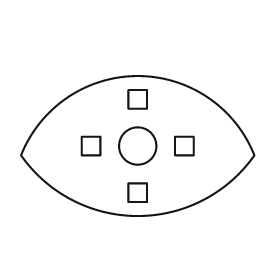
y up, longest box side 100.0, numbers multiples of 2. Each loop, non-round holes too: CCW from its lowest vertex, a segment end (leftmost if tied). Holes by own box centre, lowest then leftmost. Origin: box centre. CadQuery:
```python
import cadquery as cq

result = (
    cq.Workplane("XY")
    .moveTo(-50.0, -4.0)
    .threePointArc((0.0, -30.0), (50.0, -4.0))
    .threePointArc((0.0, 30.0), (-50.0, -4.0))
    .close()
    .moveTo(-4.0, -24.0)
    .lineTo(4.0, -24.0)
    .lineTo(4.0, -16.0)
    .lineTo(-4.0, -16.0)
    .close()
    .moveTo(-24.0, -4.0)
    .lineTo(-16.0, -4.0)
    .lineTo(-16.0, 4.0)
    .lineTo(-24.0, 4.0)
    .close()
    .moveTo(0.0, 0.0)
    .circle(8.0)
    .moveTo(16.0, -4.0)
    .lineTo(24.0, -4.0)
    .lineTo(24.0, 4.0)
    .lineTo(16.0, 4.0)
    .close()
    .moveTo(-4.0, 16.0)
    .lineTo(4.0, 16.0)
    .lineTo(4.0, 24.0)
    .lineTo(-4.0, 24.0)
    .close()
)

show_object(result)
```